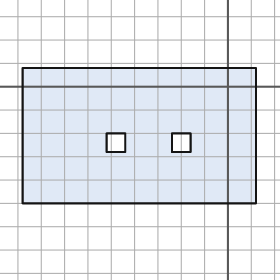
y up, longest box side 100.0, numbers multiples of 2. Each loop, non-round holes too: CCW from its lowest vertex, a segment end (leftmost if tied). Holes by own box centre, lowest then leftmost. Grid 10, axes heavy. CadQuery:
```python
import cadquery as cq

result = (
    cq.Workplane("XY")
    .moveTo(-88.0, -50.0)
    .lineTo(12.0, -50.0)
    .lineTo(12.0, 8.0)
    .lineTo(-88.0, 8.0)
    .close()
    .moveTo(-52.0, -28.0)
    .lineTo(-44.0, -28.0)
    .lineTo(-44.0, -20.0)
    .lineTo(-52.0, -20.0)
    .close()
    .moveTo(-24.0, -28.0)
    .lineTo(-16.0, -28.0)
    .lineTo(-16.0, -20.0)
    .lineTo(-24.0, -20.0)
    .close()
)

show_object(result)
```